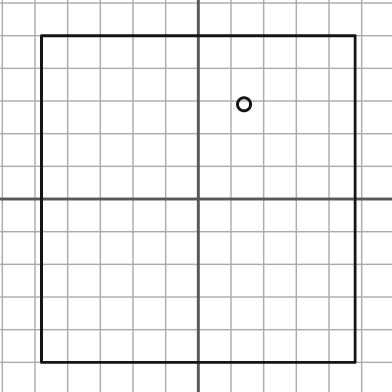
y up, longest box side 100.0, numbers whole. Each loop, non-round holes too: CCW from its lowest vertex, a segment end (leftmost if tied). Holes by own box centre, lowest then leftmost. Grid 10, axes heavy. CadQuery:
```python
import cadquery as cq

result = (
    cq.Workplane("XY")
    .moveTo(-48.0, -50.0)
    .lineTo(48.0, -50.0)
    .lineTo(48.0, 50.0)
    .lineTo(-48.0, 50.0)
    .close()
    .moveTo(14.0, 29.0)
    .circle(2.0)
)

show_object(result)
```